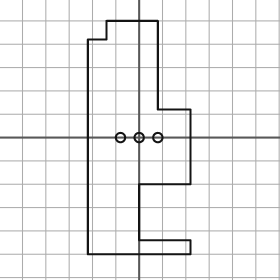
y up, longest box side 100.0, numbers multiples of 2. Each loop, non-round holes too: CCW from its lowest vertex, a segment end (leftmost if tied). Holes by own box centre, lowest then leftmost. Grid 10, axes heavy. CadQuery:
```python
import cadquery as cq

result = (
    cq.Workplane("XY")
    .moveTo(-22.0, -50.0)
    .lineTo(22.0, -50.0)
    .lineTo(22.0, -44.0)
    .lineTo(0.0, -44.0)
    .lineTo(0.0, -20.0)
    .lineTo(22.0, -20.0)
    .lineTo(22.0, 12.0)
    .lineTo(8.0, 12.0)
    .lineTo(8.0, 50.0)
    .lineTo(-14.0, 50.0)
    .lineTo(-14.0, 42.0)
    .lineTo(-22.0, 42.0)
    .close()
    .moveTo(-8.0, 0.0)
    .circle(2.0)
    .moveTo(0.0, 0.0)
    .circle(2.0)
    .moveTo(8.0, 0.0)
    .circle(2.0)
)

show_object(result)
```